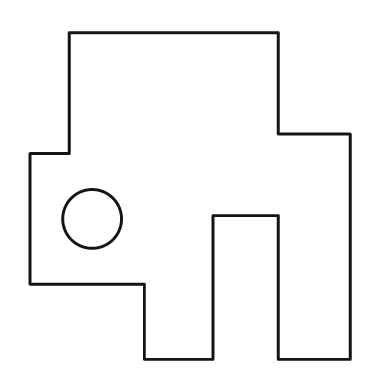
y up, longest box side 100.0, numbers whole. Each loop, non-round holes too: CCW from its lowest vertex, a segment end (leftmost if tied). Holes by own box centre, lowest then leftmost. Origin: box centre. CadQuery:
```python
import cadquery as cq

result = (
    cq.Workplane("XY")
    .moveTo(-14.0, -50.0)
    .lineTo(7.0, -50.0)
    .lineTo(7.0, -6.0)
    .lineTo(27.0, -6.0)
    .lineTo(27.0, -50.0)
    .lineTo(49.0, -50.0)
    .lineTo(49.0, 19.0)
    .lineTo(27.0, 19.0)
    .lineTo(27.0, 50.0)
    .lineTo(-37.0, 50.0)
    .lineTo(-37.0, 13.0)
    .lineTo(-49.0, 13.0)
    .lineTo(-49.0, -27.0)
    .lineTo(-14.0, -27.0)
    .close()
    .moveTo(-30.0, -7.0)
    .circle(9.0)
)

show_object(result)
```